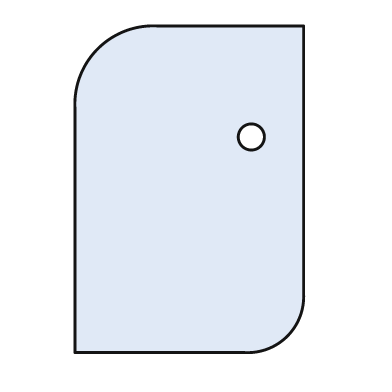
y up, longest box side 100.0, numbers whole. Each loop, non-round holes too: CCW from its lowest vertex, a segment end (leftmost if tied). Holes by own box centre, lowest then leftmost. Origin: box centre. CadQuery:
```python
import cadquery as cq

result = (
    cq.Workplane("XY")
    .moveTo(-35.0, -50.0)
    .lineTo(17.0, -50.0)
    .threePointArc((30.0, -45.0), (35.0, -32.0))
    .lineTo(35.0, 50.0)
    .lineTo(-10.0, 50.0)
    .threePointArc((-28.0, 43.0), (-35.0, 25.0))
    .close()
    .moveTo(19.0, 16.0)
    .circle(4.0)
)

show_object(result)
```